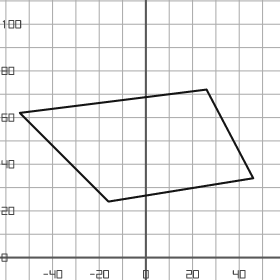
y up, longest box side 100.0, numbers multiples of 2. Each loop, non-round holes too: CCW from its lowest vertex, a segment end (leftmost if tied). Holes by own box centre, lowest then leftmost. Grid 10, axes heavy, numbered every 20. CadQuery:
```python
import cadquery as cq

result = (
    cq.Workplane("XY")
    .moveTo(-16.0, 24.0)
    .lineTo(46.0, 34.0)
    .lineTo(26.0, 72.0)
    .lineTo(-54.0, 62.0)
    .close()
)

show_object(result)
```